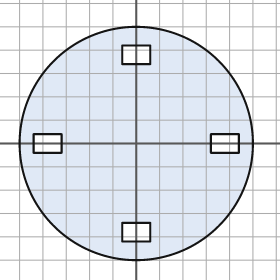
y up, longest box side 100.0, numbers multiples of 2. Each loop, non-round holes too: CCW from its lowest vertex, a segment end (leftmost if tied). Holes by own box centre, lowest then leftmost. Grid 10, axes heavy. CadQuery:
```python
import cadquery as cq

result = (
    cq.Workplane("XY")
    .moveTo(0.0, 0.0)
    .circle(50.0)
    .moveTo(-6.0, -42.0)
    .lineTo(6.0, -42.0)
    .lineTo(6.0, -34.0)
    .lineTo(-6.0, -34.0)
    .close()
    .moveTo(-44.0, -4.0)
    .lineTo(-32.0, -4.0)
    .lineTo(-32.0, 4.0)
    .lineTo(-44.0, 4.0)
    .close()
    .moveTo(32.0, -4.0)
    .lineTo(44.0, -4.0)
    .lineTo(44.0, 4.0)
    .lineTo(32.0, 4.0)
    .close()
    .moveTo(-6.0, 34.0)
    .lineTo(6.0, 34.0)
    .lineTo(6.0, 42.0)
    .lineTo(-6.0, 42.0)
    .close()
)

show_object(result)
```